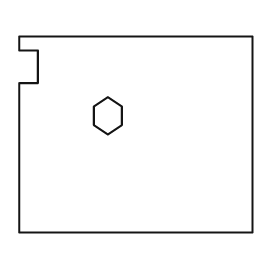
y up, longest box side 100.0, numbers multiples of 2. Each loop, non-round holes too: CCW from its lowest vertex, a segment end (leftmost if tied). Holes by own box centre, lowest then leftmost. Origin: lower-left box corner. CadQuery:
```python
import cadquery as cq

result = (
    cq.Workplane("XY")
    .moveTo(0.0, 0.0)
    .lineTo(100.0, 0.0)
    .lineTo(100.0, 84.0)
    .lineTo(0.0, 84.0)
    .lineTo(0.0, 78.0)
    .lineTo(8.0, 78.0)
    .lineTo(8.0, 64.0)
    .lineTo(0.0, 64.0)
    .close()
    .moveTo(38.0, 42.0)
    .lineTo(44.0, 46.0)
    .lineTo(44.0, 54.0)
    .lineTo(38.0, 58.0)
    .lineTo(32.0, 54.0)
    .lineTo(32.0, 46.0)
    .close()
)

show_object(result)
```